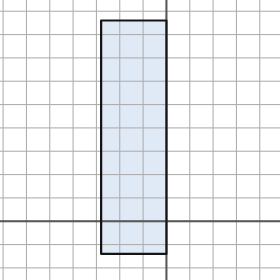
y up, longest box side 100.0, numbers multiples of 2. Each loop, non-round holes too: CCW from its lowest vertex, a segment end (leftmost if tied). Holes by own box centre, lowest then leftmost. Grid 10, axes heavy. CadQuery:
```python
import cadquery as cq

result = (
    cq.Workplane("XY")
    .moveTo(-28.0, -14.0)
    .lineTo(0.0, -14.0)
    .lineTo(0.0, 86.0)
    .lineTo(-28.0, 86.0)
    .close()
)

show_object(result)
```